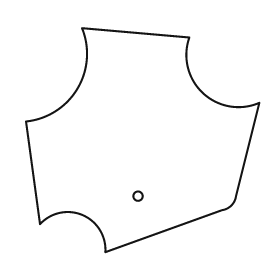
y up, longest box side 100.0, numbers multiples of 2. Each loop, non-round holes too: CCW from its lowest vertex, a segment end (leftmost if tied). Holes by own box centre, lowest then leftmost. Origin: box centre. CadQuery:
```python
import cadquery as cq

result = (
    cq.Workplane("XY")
    .moveTo(-16.0, -48.0)
    .lineTo(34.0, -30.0)
    .threePointArc((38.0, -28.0), (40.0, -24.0))
    .lineTo(50.0, 16.0)
    .threePointArc((26.0, 20.0), (20.0, 44.0))
    .lineTo(-26.0, 48.0)
    .threePointArc((-28.0, 22.0), (-50.0, 8.0))
    .lineTo(-44.0, -36.0)
    .threePointArc((-26.0, -32.0), (-16.0, -48.0))
    .close()
    .moveTo(-2.0, -24.0)
    .circle(2.0)
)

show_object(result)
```